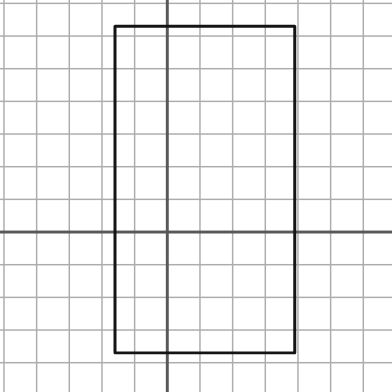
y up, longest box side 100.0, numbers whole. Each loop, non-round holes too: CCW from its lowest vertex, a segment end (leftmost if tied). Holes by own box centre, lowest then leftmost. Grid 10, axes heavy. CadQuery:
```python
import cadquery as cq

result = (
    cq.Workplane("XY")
    .moveTo(-16.0, -37.0)
    .lineTo(39.0, -37.0)
    .lineTo(39.0, 63.0)
    .lineTo(-16.0, 63.0)
    .close()
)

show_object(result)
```